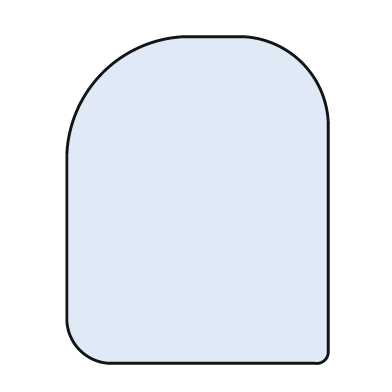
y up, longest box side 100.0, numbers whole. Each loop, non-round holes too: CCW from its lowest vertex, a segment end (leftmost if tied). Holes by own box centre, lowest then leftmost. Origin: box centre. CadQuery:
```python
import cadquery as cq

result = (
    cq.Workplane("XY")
    .moveTo(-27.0, -50.0)
    .lineTo(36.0, -50.0)
    .threePointArc((39.0, -49.0), (40.0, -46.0))
    .lineTo(40.0, 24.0)
    .threePointArc((32.0, 42.0), (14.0, 50.0))
    .lineTo(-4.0, 50.0)
    .threePointArc((-29.0, 39.0), (-40.0, 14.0))
    .lineTo(-40.0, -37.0)
    .threePointArc((-36.0, -46.0), (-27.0, -50.0))
    .close()
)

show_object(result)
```